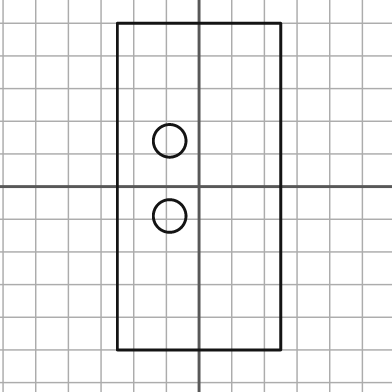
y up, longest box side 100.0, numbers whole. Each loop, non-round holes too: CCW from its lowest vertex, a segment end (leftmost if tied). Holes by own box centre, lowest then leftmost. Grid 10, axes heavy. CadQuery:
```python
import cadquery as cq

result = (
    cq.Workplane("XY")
    .moveTo(-25.0, -50.0)
    .lineTo(25.0, -50.0)
    .lineTo(25.0, 50.0)
    .lineTo(-25.0, 50.0)
    .close()
    .moveTo(-9.0, -9.0)
    .circle(5.0)
    .moveTo(-9.0, 14.0)
    .circle(5.0)
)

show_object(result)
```